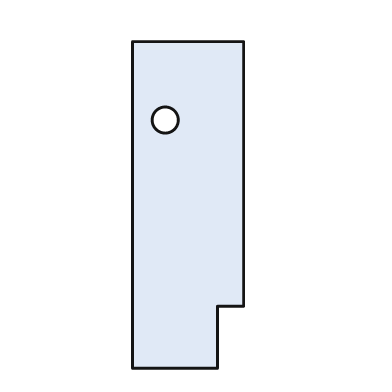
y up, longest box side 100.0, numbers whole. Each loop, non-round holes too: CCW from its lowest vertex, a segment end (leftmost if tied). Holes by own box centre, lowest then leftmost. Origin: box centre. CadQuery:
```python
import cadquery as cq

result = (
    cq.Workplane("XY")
    .moveTo(-17.0, -50.0)
    .lineTo(9.0, -50.0)
    .lineTo(9.0, -31.0)
    .lineTo(17.0, -31.0)
    .lineTo(17.0, 50.0)
    .lineTo(-17.0, 50.0)
    .close()
    .moveTo(-7.0, 26.0)
    .circle(4.0)
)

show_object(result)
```